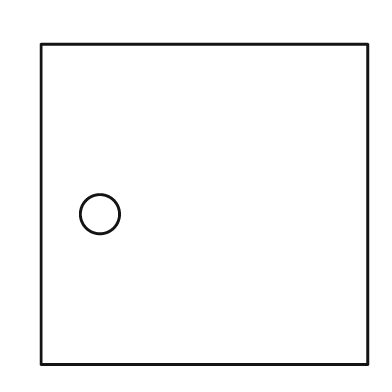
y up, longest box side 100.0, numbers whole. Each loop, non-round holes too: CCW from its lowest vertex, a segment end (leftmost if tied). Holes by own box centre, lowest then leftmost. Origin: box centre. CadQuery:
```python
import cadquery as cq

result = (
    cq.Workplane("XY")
    .moveTo(-50.0, -49.0)
    .lineTo(50.0, -49.0)
    .lineTo(50.0, 49.0)
    .lineTo(-50.0, 49.0)
    .close()
    .moveTo(-32.0, -3.0)
    .circle(6.0)
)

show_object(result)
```